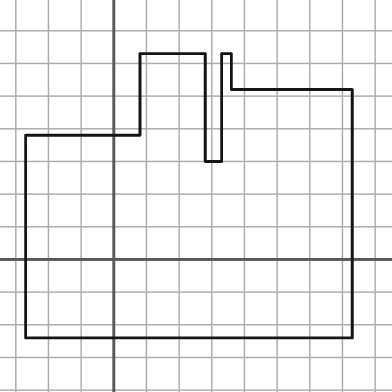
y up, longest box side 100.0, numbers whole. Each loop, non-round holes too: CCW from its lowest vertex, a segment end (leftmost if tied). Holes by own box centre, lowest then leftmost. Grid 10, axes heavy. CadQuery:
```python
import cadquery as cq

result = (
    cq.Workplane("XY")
    .moveTo(-27.0, -24.0)
    .lineTo(73.0, -24.0)
    .lineTo(73.0, 52.0)
    .lineTo(36.0, 52.0)
    .lineTo(36.0, 63.0)
    .lineTo(33.0, 63.0)
    .lineTo(33.0, 30.0)
    .lineTo(28.0, 30.0)
    .lineTo(28.0, 63.0)
    .lineTo(8.0, 63.0)
    .lineTo(8.0, 38.0)
    .lineTo(-27.0, 38.0)
    .close()
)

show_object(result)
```